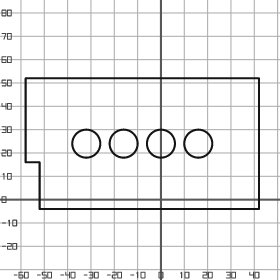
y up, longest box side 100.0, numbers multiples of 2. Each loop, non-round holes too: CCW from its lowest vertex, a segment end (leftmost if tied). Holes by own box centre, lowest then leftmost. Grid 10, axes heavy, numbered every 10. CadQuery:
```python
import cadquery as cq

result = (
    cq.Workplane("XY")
    .moveTo(-52.0, -4.0)
    .lineTo(42.0, -4.0)
    .lineTo(42.0, 52.0)
    .lineTo(-58.0, 52.0)
    .lineTo(-58.0, 16.0)
    .lineTo(-52.0, 16.0)
    .close()
    .moveTo(-32.0, 24.0)
    .circle(6.0)
    .moveTo(-16.0, 24.0)
    .circle(6.0)
    .moveTo(0.0, 24.0)
    .circle(6.0)
    .moveTo(16.0, 24.0)
    .circle(6.0)
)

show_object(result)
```